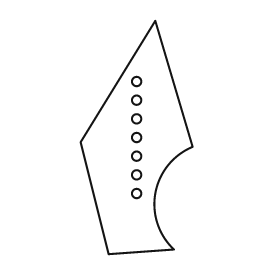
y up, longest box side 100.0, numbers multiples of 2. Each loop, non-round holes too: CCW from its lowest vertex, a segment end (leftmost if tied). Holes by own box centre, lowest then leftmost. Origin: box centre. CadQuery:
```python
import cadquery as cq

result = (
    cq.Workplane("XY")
    .moveTo(-12.0, -50.0)
    .lineTo(16.0, -48.0)
    .threePointArc((8.0, -24.0), (24.0, -4.0))
    .lineTo(8.0, 50.0)
    .lineTo(-24.0, -2.0)
    .close()
    .moveTo(0.0, -24.0)
    .circle(2.0)
    .moveTo(0.0, -16.0)
    .circle(2.0)
    .moveTo(0.0, -8.0)
    .circle(2.0)
    .moveTo(0.0, 0.0)
    .circle(2.0)
    .moveTo(0.0, 8.0)
    .circle(2.0)
    .moveTo(0.0, 16.0)
    .circle(2.0)
    .moveTo(0.0, 24.0)
    .circle(2.0)
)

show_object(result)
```